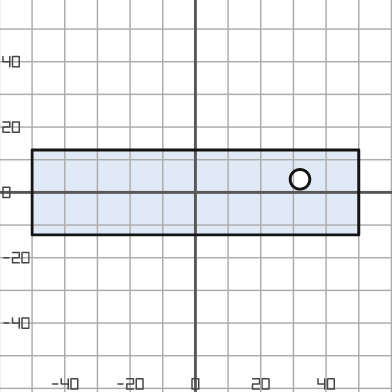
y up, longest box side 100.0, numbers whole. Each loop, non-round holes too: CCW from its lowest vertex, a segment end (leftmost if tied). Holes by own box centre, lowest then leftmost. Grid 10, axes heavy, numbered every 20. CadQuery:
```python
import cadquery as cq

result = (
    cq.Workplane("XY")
    .moveTo(-50.0, -13.0)
    .lineTo(50.0, -13.0)
    .lineTo(50.0, 13.0)
    .lineTo(-50.0, 13.0)
    .close()
    .moveTo(32.0, 4.0)
    .circle(3.0)
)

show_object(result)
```